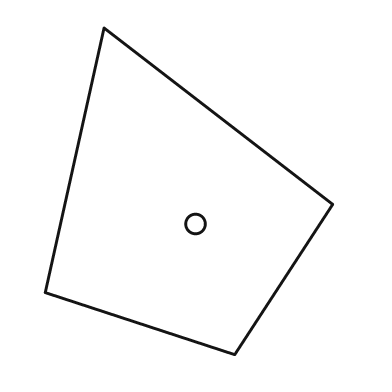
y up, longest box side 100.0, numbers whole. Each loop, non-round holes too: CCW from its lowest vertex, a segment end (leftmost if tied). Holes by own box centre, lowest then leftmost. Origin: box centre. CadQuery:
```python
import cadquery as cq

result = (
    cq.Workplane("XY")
    .moveTo(14.0, -50.0)
    .lineTo(44.0, -4.0)
    .lineTo(-26.0, 50.0)
    .lineTo(-44.0, -31.0)
    .close()
    .moveTo(2.0, -10.0)
    .circle(3.0)
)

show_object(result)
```